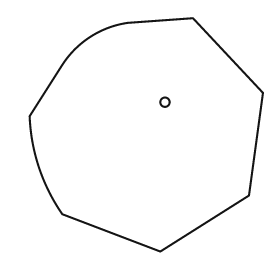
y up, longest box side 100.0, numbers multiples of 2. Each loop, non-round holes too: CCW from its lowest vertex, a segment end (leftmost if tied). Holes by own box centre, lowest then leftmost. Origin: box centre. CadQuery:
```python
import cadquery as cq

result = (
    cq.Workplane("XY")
    .moveTo(6.0, -50.0)
    .lineTo(44.0, -26.0)
    .lineTo(50.0, 18.0)
    .lineTo(20.0, 50.0)
    .lineTo(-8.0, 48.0)
    .threePointArc((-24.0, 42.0), (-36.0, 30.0))
    .lineTo(-50.0, 8.0)
    .threePointArc((-46.0, -14.0), (-36.0, -34.0))
    .close()
    .moveTo(8.0, 14.0)
    .circle(2.0)
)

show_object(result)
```